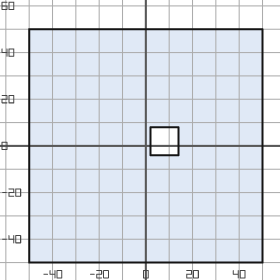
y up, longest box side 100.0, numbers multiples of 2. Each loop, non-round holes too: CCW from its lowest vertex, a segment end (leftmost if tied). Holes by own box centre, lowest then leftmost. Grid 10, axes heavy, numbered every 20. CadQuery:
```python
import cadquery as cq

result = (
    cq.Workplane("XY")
    .moveTo(-50.0, -50.0)
    .lineTo(50.0, -50.0)
    .lineTo(50.0, 50.0)
    .lineTo(-50.0, 50.0)
    .close()
    .moveTo(2.0, -4.0)
    .lineTo(14.0, -4.0)
    .lineTo(14.0, 8.0)
    .lineTo(2.0, 8.0)
    .close()
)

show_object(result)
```